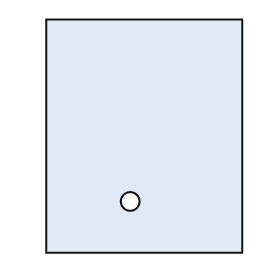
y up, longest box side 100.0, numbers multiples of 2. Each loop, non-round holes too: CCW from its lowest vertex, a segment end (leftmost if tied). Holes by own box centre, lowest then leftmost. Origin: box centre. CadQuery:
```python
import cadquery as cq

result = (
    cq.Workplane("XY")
    .moveTo(-42.0, -50.0)
    .lineTo(42.0, -50.0)
    .lineTo(42.0, 50.0)
    .lineTo(-42.0, 50.0)
    .close()
    .moveTo(-6.0, -28.0)
    .circle(4.0)
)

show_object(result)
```